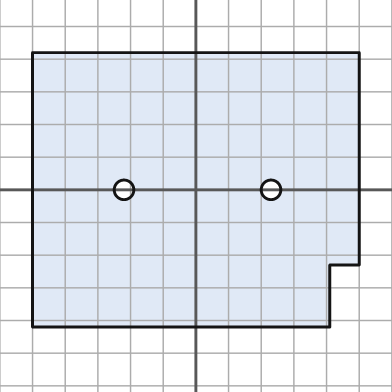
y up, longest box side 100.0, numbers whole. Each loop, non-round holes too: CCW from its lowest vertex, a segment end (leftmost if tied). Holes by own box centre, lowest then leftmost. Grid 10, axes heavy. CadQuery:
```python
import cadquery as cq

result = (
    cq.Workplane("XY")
    .moveTo(-50.0, -42.0)
    .lineTo(41.0, -42.0)
    .lineTo(41.0, -23.0)
    .lineTo(50.0, -23.0)
    .lineTo(50.0, 42.0)
    .lineTo(-50.0, 42.0)
    .close()
    .moveTo(-22.0, 0.0)
    .circle(3.0)
    .moveTo(23.0, 0.0)
    .circle(3.0)
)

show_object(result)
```